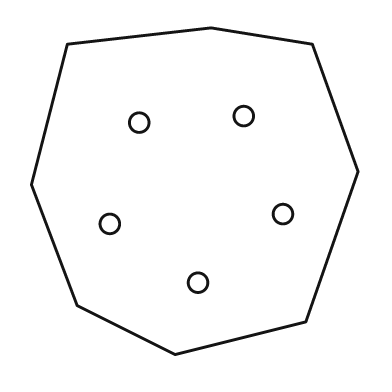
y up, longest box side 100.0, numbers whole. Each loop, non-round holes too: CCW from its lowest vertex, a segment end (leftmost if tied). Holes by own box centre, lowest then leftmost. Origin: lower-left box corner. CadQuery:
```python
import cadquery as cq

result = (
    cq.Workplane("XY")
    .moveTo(44.0, 0.0)
    .lineTo(84.0, 10.0)
    .lineTo(100.0, 56.0)
    .lineTo(86.0, 95.0)
    .lineTo(55.0, 100.0)
    .lineTo(11.0, 95.0)
    .lineTo(0.0, 52.0)
    .lineTo(14.0, 15.0)
    .close()
    .moveTo(51.0, 22.0)
    .circle(3.0)
    .moveTo(24.0, 40.0)
    .circle(3.0)
    .moveTo(77.0, 43.0)
    .circle(3.0)
    .moveTo(33.0, 71.0)
    .circle(3.0)
    .moveTo(65.0, 73.0)
    .circle(3.0)
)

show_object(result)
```